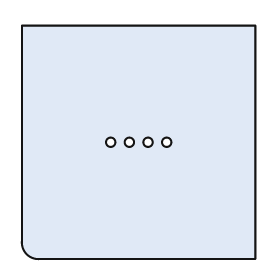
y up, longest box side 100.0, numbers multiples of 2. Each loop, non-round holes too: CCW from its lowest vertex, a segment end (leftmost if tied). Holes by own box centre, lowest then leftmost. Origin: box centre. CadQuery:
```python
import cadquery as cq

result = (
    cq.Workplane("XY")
    .moveTo(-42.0, -50.0)
    .lineTo(50.0, -50.0)
    .lineTo(50.0, 50.0)
    .lineTo(-50.0, 50.0)
    .lineTo(-50.0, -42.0)
    .threePointArc((-48.0, -48.0), (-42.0, -50.0))
    .close()
    .moveTo(-12.0, 0.0)
    .circle(2.0)
    .moveTo(-4.0, 0.0)
    .circle(2.0)
    .moveTo(4.0, 0.0)
    .circle(2.0)
    .moveTo(12.0, 0.0)
    .circle(2.0)
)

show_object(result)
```